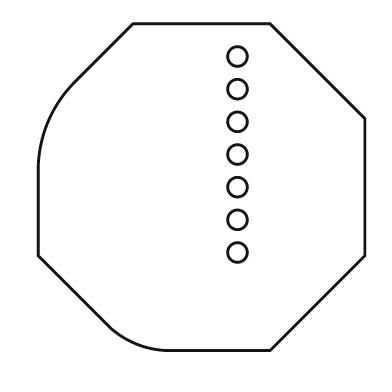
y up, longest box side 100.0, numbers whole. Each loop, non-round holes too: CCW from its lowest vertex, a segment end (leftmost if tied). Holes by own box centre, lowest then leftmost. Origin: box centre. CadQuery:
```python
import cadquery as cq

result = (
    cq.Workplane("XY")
    .moveTo(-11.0, -50.0)
    .lineTo(21.0, -50.0)
    .lineTo(50.0, -21.0)
    .lineTo(50.0, 21.0)
    .lineTo(21.0, 50.0)
    .lineTo(-21.0, 50.0)
    .lineTo(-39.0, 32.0)
    .threePointArc((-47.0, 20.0), (-50.0, 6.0))
    .lineTo(-50.0, -21.0)
    .lineTo(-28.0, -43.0)
    .threePointArc((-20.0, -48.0), (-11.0, -50.0))
    .close()
    .moveTo(11.0, -20.0)
    .circle(3.0)
    .moveTo(11.0, -10.0)
    .circle(3.0)
    .moveTo(11.0, 0.0)
    .circle(3.0)
    .moveTo(11.0, 10.0)
    .circle(3.0)
    .moveTo(11.0, 20.0)
    .circle(3.0)
    .moveTo(11.0, 30.0)
    .circle(3.0)
    .moveTo(11.0, 40.0)
    .circle(3.0)
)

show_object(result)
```